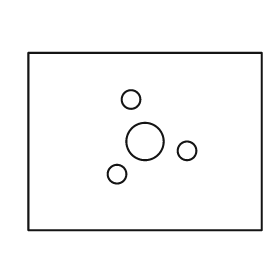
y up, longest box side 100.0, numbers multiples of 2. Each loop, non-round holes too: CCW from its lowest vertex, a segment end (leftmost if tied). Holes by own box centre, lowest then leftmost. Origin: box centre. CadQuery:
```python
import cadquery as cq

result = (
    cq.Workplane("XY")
    .moveTo(-50.0, -38.0)
    .lineTo(50.0, -38.0)
    .lineTo(50.0, 38.0)
    .lineTo(-50.0, 38.0)
    .close()
    .moveTo(-12.0, -14.0)
    .circle(4.0)
    .moveTo(18.0, -4.0)
    .circle(4.0)
    .moveTo(0.0, 0.0)
    .circle(8.0)
    .moveTo(-6.0, 18.0)
    .circle(4.0)
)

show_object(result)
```